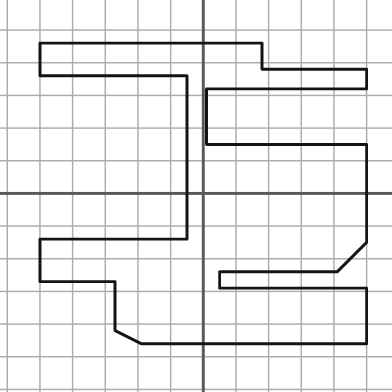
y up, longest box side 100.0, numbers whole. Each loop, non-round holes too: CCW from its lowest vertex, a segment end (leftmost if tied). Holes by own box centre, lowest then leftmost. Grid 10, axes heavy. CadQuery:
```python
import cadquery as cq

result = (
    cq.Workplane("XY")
    .moveTo(-19.0, -46.0)
    .lineTo(50.0, -46.0)
    .lineTo(50.0, -29.0)
    .lineTo(5.0, -29.0)
    .lineTo(5.0, -24.0)
    .lineTo(41.0, -24.0)
    .lineTo(50.0, -15.0)
    .lineTo(50.0, 15.0)
    .lineTo(1.0, 15.0)
    .lineTo(1.0, 32.0)
    .lineTo(50.0, 32.0)
    .lineTo(50.0, 38.0)
    .lineTo(18.0, 38.0)
    .lineTo(18.0, 46.0)
    .lineTo(-50.0, 46.0)
    .lineTo(-50.0, 36.0)
    .lineTo(-5.0, 36.0)
    .lineTo(-5.0, -14.0)
    .lineTo(-50.0, -14.0)
    .lineTo(-50.0, -27.0)
    .lineTo(-27.0, -27.0)
    .lineTo(-27.0, -42.0)
    .close()
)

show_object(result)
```